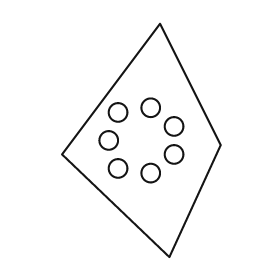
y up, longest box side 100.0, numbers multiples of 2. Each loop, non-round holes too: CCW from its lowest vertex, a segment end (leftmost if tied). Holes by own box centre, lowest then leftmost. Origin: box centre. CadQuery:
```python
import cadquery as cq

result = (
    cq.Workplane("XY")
    .moveTo(12.0, -50.0)
    .lineTo(34.0, -2.0)
    .lineTo(8.0, 50.0)
    .lineTo(-34.0, -6.0)
    .close()
    .moveTo(4.0, -14.0)
    .circle(4.0)
    .moveTo(-10.0, -12.0)
    .circle(4.0)
    .moveTo(14.0, -6.0)
    .circle(4.0)
    .moveTo(-14.0, 0.0)
    .circle(4.0)
    .moveTo(14.0, 6.0)
    .circle(4.0)
    .moveTo(-10.0, 12.0)
    .circle(4.0)
    .moveTo(4.0, 14.0)
    .circle(4.0)
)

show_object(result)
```